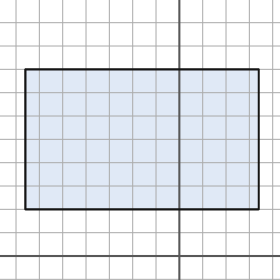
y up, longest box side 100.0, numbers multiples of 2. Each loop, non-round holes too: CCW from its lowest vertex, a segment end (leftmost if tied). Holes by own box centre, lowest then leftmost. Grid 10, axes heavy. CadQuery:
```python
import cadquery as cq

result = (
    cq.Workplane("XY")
    .moveTo(-66.0, 20.0)
    .lineTo(34.0, 20.0)
    .lineTo(34.0, 80.0)
    .lineTo(-66.0, 80.0)
    .close()
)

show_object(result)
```